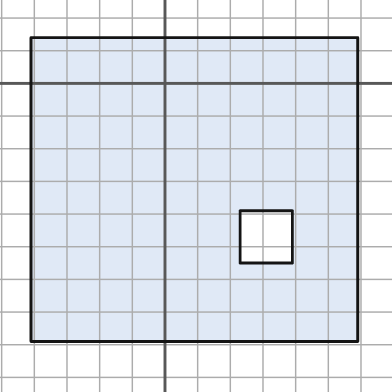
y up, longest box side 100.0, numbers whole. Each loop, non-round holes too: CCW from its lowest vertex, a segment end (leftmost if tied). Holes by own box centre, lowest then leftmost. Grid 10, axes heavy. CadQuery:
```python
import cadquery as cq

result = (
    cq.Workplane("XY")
    .moveTo(-41.0, -79.0)
    .lineTo(59.0, -79.0)
    .lineTo(59.0, 14.0)
    .lineTo(-41.0, 14.0)
    .close()
    .moveTo(23.0, -55.0)
    .lineTo(39.0, -55.0)
    .lineTo(39.0, -39.0)
    .lineTo(23.0, -39.0)
    .close()
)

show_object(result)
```